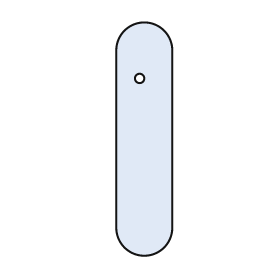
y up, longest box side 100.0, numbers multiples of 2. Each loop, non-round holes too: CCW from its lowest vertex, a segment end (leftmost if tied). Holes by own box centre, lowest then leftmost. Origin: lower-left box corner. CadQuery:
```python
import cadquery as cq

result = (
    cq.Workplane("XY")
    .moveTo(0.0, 12.0)
    .threePointArc((12.0, 0.0), (24.0, 12.0))
    .lineTo(24.0, 88.0)
    .threePointArc((12.0, 100.0), (0.0, 88.0))
    .close()
    .moveTo(10.0, 76.0)
    .circle(2.0)
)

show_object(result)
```